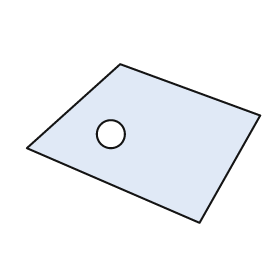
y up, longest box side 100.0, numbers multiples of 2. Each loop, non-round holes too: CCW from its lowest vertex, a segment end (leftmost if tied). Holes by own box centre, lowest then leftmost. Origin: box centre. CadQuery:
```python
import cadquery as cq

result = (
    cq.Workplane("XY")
    .moveTo(24.0, -34.0)
    .lineTo(50.0, 12.0)
    .lineTo(-10.0, 34.0)
    .lineTo(-50.0, -2.0)
    .close()
    .moveTo(-14.0, 4.0)
    .circle(6.0)
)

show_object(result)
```